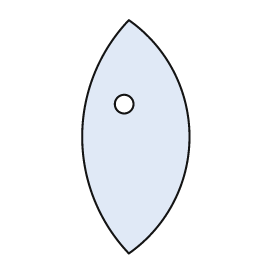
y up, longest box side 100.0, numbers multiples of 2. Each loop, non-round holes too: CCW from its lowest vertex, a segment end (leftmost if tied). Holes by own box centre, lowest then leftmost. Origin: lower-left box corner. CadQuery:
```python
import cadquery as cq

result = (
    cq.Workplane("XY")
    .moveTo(20.0, 0.0)
    .threePointArc((46.0, 50.0), (20.0, 100.0))
    .threePointArc((0.0, 50.0), (20.0, 0.0))
    .close()
    .moveTo(18.0, 64.0)
    .circle(4.0)
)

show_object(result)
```